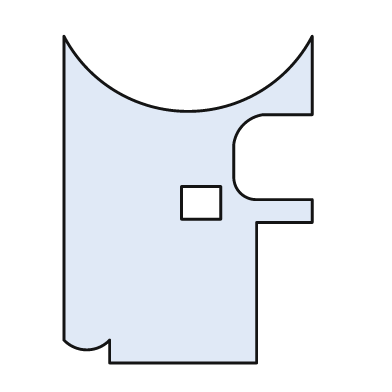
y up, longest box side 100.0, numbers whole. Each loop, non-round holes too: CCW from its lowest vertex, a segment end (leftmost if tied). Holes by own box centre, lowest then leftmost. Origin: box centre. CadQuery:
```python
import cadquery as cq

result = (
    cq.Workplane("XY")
    .moveTo(-24.0, -50.0)
    .lineTo(21.0, -50.0)
    .lineTo(21.0, -7.0)
    .lineTo(38.0, -7.0)
    .lineTo(38.0, 0.0)
    .lineTo(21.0, 0.0)
    .threePointArc((16.0, 2.0), (14.0, 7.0))
    .lineTo(14.0, 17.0)
    .threePointArc((17.0, 23.0), (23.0, 26.0))
    .lineTo(38.0, 26.0)
    .lineTo(38.0, 50.0)
    .threePointArc((0.0, 27.0), (-38.0, 50.0))
    .lineTo(-38.0, -43.0)
    .threePointArc((-31.0, -46.0), (-24.0, -43.0))
    .close()
    .moveTo(-2.0, -6.0)
    .lineTo(10.0, -6.0)
    .lineTo(10.0, 4.0)
    .lineTo(-2.0, 4.0)
    .close()
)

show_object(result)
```